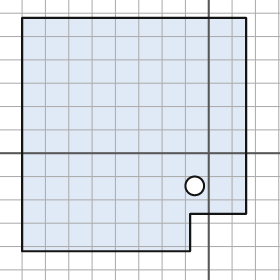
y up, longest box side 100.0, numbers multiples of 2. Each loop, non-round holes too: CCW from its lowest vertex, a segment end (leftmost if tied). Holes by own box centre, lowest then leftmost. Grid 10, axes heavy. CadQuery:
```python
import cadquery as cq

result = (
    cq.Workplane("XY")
    .moveTo(-80.0, -42.0)
    .lineTo(-8.0, -42.0)
    .lineTo(-8.0, -26.0)
    .lineTo(16.0, -26.0)
    .lineTo(16.0, 58.0)
    .lineTo(-80.0, 58.0)
    .close()
    .moveTo(-6.0, -14.0)
    .circle(4.0)
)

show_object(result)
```